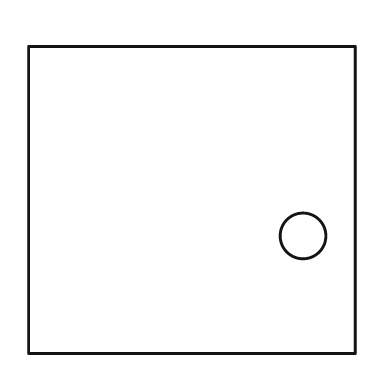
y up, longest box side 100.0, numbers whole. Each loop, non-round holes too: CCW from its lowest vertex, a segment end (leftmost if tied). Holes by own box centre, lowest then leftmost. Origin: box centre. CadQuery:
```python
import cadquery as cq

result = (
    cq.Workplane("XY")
    .moveTo(-50.0, -47.0)
    .lineTo(50.0, -47.0)
    .lineTo(50.0, 47.0)
    .lineTo(-50.0, 47.0)
    .close()
    .moveTo(34.0, -11.0)
    .circle(7.0)
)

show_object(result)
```